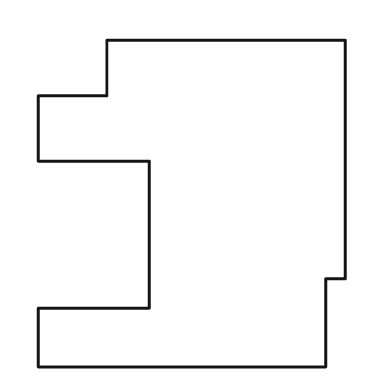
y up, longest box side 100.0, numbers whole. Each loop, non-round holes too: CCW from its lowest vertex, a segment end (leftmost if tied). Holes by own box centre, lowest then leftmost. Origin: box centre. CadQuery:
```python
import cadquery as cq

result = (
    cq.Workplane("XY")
    .moveTo(-47.0, -50.0)
    .lineTo(41.0, -50.0)
    .lineTo(41.0, -23.0)
    .lineTo(47.0, -23.0)
    .lineTo(47.0, 50.0)
    .lineTo(-26.0, 50.0)
    .lineTo(-26.0, 33.0)
    .lineTo(-47.0, 33.0)
    .lineTo(-47.0, 13.0)
    .lineTo(-13.0, 13.0)
    .lineTo(-13.0, -32.0)
    .lineTo(-47.0, -32.0)
    .close()
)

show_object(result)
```